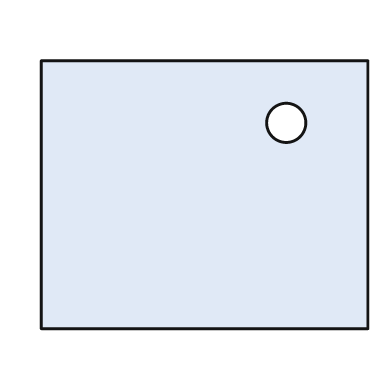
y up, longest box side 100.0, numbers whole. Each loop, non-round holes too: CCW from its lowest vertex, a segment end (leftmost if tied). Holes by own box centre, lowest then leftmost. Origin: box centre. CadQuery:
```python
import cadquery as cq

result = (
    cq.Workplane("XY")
    .moveTo(-50.0, -41.0)
    .lineTo(50.0, -41.0)
    .lineTo(50.0, 41.0)
    .lineTo(-50.0, 41.0)
    .close()
    .moveTo(25.0, 22.0)
    .circle(6.0)
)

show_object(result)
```